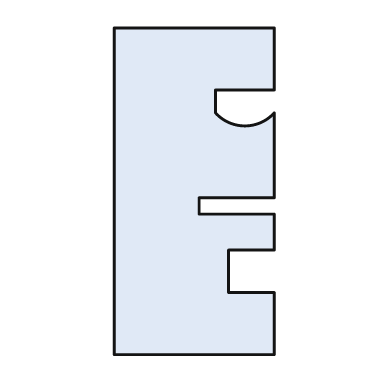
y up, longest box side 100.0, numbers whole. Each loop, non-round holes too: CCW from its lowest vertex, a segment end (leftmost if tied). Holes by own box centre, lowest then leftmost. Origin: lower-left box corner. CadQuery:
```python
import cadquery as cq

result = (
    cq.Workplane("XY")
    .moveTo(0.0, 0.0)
    .lineTo(49.0, 0.0)
    .lineTo(49.0, 19.0)
    .lineTo(35.0, 19.0)
    .lineTo(35.0, 32.0)
    .lineTo(49.0, 32.0)
    .lineTo(49.0, 43.0)
    .lineTo(26.0, 43.0)
    .lineTo(26.0, 48.0)
    .lineTo(49.0, 48.0)
    .lineTo(49.0, 74.0)
    .threePointArc((40.0, 70.0), (31.0, 74.0))
    .lineTo(31.0, 81.0)
    .lineTo(49.0, 81.0)
    .lineTo(49.0, 100.0)
    .lineTo(0.0, 100.0)
    .close()
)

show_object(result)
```